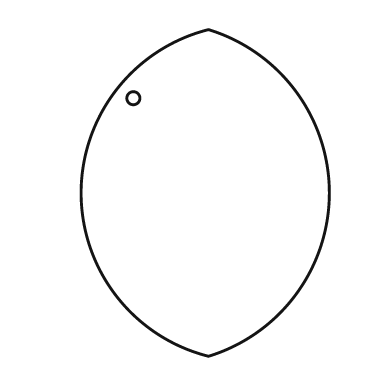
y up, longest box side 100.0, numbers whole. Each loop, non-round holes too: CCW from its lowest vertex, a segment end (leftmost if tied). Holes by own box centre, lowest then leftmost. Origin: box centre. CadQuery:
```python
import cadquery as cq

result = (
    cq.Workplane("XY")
    .moveTo(1.0, -50.0)
    .threePointArc((38.0, 0.0), (1.0, 50.0))
    .threePointArc((-38.0, 0.0), (1.0, -50.0))
    .close()
    .moveTo(-22.0, 29.0)
    .circle(2.0)
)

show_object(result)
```